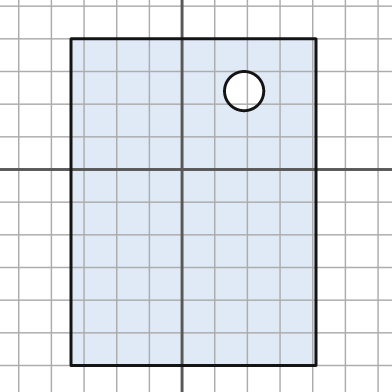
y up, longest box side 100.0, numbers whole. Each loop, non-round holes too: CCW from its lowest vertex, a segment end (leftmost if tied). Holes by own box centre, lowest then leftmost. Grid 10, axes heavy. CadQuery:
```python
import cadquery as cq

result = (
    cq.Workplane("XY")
    .moveTo(-34.0, -60.0)
    .lineTo(41.0, -60.0)
    .lineTo(41.0, 40.0)
    .lineTo(-34.0, 40.0)
    .close()
    .moveTo(19.0, 24.0)
    .circle(6.0)
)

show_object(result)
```